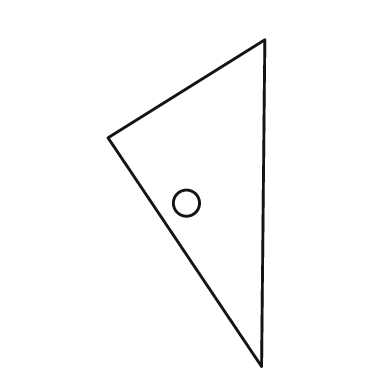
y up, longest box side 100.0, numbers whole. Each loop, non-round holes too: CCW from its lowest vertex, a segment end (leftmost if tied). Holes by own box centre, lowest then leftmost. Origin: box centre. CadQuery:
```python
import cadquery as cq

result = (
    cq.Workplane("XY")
    .moveTo(23.0, -50.0)
    .lineTo(24.0, 50.0)
    .lineTo(-24.0, 20.0)
    .close()
    .moveTo(0.0, 0.0)
    .circle(4.0)
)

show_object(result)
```